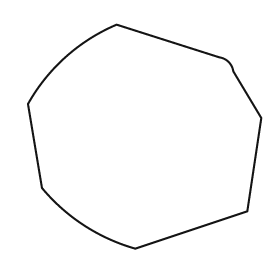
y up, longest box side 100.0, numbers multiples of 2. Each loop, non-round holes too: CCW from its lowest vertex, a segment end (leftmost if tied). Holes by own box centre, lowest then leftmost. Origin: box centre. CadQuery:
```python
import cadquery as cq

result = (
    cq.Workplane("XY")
    .moveTo(-4.0, -48.0)
    .lineTo(44.0, -32.0)
    .lineTo(50.0, 8.0)
    .lineTo(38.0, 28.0)
    .threePointArc((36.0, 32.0), (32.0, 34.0))
    .lineTo(-12.0, 48.0)
    .threePointArc((-34.0, 34.0), (-50.0, 14.0))
    .lineTo(-44.0, -22.0)
    .threePointArc((-26.0, -38.0), (-4.0, -48.0))
    .close()
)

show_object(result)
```